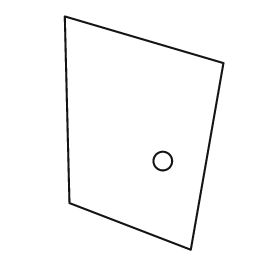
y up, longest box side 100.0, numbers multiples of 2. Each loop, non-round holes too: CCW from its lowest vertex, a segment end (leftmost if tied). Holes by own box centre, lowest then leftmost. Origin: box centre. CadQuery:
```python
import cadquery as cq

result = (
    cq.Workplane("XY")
    .moveTo(20.0, -50.0)
    .lineTo(34.0, 30.0)
    .lineTo(-34.0, 50.0)
    .lineTo(-32.0, -30.0)
    .close()
    .moveTo(8.0, -12.0)
    .circle(4.0)
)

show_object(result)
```